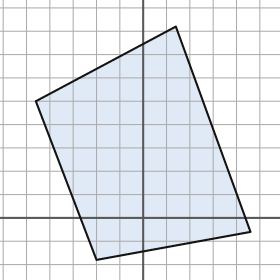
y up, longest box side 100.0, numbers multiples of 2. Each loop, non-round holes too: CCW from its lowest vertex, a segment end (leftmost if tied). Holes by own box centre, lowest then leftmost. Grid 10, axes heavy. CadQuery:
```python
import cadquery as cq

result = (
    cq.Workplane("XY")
    .moveTo(-20.0, -18.0)
    .lineTo(46.0, -6.0)
    .lineTo(14.0, 82.0)
    .lineTo(-46.0, 50.0)
    .close()
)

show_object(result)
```